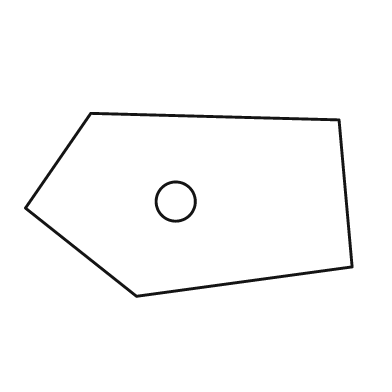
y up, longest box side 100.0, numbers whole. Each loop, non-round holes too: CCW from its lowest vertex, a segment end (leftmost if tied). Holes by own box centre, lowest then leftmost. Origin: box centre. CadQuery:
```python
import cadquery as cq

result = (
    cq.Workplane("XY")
    .moveTo(-16.0, -28.0)
    .lineTo(50.0, -19.0)
    .lineTo(46.0, 26.0)
    .lineTo(-30.0, 28.0)
    .lineTo(-50.0, -1.0)
    .close()
    .moveTo(-4.0, 1.0)
    .circle(6.0)
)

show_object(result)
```